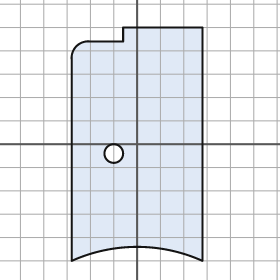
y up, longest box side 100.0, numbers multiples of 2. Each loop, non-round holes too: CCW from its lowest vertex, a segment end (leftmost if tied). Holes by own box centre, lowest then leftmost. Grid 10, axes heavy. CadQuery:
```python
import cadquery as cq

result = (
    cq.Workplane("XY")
    .moveTo(-28.0, -50.0)
    .threePointArc((0.0, -44.0), (28.0, -50.0))
    .lineTo(28.0, 50.0)
    .lineTo(-6.0, 50.0)
    .lineTo(-6.0, 44.0)
    .lineTo(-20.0, 44.0)
    .threePointArc((-26.0, 42.0), (-28.0, 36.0))
    .close()
    .moveTo(-10.0, -4.0)
    .circle(4.0)
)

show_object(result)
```